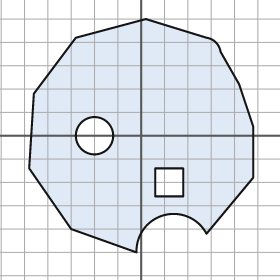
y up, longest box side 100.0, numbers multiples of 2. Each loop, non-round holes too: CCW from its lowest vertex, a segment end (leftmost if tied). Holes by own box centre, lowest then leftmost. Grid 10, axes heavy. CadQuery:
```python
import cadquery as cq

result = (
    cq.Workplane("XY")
    .moveTo(-2.0, -50.0)
    .threePointArc((10.0, -34.0), (28.0, -42.0))
    .lineTo(48.0, -18.0)
    .lineTo(48.0, 4.0)
    .lineTo(42.0, 22.0)
    .lineTo(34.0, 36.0)
    .threePointArc((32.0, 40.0), (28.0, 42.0))
    .lineTo(2.0, 50.0)
    .lineTo(-28.0, 42.0)
    .lineTo(-46.0, 18.0)
    .lineTo(-48.0, -14.0)
    .lineTo(-30.0, -40.0)
    .close()
    .moveTo(6.0, -26.0)
    .lineTo(18.0, -26.0)
    .lineTo(18.0, -14.0)
    .lineTo(6.0, -14.0)
    .close()
    .moveTo(-20.0, 0.0)
    .circle(8.0)
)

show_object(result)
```